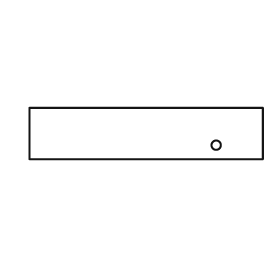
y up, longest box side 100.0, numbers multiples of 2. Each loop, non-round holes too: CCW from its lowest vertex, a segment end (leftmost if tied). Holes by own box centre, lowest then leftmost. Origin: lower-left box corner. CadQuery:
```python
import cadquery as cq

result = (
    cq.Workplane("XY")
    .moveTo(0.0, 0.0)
    .lineTo(100.0, 0.0)
    .lineTo(100.0, 22.0)
    .lineTo(0.0, 22.0)
    .close()
    .moveTo(80.0, 6.0)
    .circle(2.0)
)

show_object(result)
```